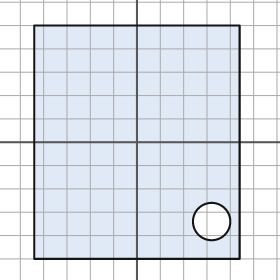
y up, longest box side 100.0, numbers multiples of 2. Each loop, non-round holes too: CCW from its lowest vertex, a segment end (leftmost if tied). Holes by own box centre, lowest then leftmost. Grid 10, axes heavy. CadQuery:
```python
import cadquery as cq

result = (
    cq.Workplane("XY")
    .moveTo(-44.0, -50.0)
    .lineTo(44.0, -50.0)
    .lineTo(44.0, 50.0)
    .lineTo(-44.0, 50.0)
    .close()
    .moveTo(32.0, -34.0)
    .circle(8.0)
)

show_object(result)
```